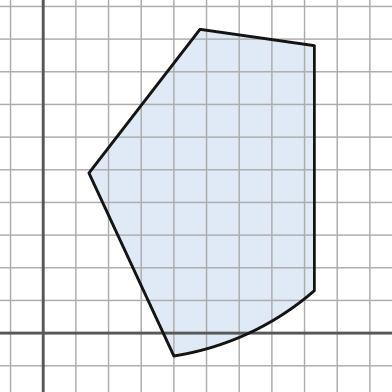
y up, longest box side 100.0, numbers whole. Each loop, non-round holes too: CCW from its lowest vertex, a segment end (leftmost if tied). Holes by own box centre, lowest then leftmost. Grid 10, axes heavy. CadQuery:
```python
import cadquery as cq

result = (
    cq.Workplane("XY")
    .moveTo(40.0, -7.0)
    .threePointArc((63.0, 0.0), (83.0, 13.0))
    .lineTo(83.0, 88.0)
    .lineTo(48.0, 93.0)
    .lineTo(14.0, 49.0)
    .close()
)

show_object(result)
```